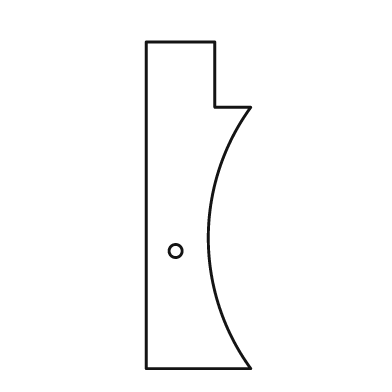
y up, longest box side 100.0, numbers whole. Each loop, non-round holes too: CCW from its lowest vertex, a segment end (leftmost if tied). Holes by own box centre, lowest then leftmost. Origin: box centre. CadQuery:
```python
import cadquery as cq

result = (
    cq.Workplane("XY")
    .moveTo(-16.0, -50.0)
    .lineTo(16.0, -50.0)
    .threePointArc((3.0, -10.0), (16.0, 30.0))
    .lineTo(5.0, 30.0)
    .lineTo(5.0, 50.0)
    .lineTo(-16.0, 50.0)
    .close()
    .moveTo(-7.0, -14.0)
    .circle(2.0)
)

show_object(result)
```